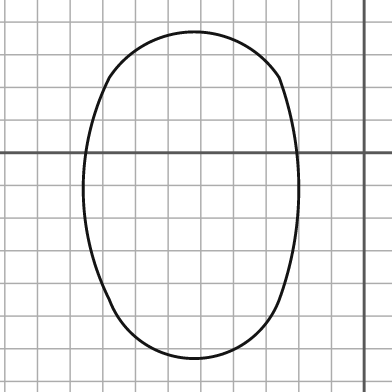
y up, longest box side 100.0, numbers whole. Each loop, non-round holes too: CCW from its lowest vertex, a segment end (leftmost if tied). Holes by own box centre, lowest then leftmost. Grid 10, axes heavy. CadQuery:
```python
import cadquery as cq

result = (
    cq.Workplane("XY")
    .moveTo(-78.0, -45.0)
    .threePointArc((-52.0, -63.0), (-26.0, -45.0))
    .threePointArc((-20.0, -11.0), (-26.0, 23.0))
    .threePointArc((-52.0, 37.0), (-78.0, 23.0))
    .threePointArc((-86.0, -11.0), (-78.0, -45.0))
    .close()
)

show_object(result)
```